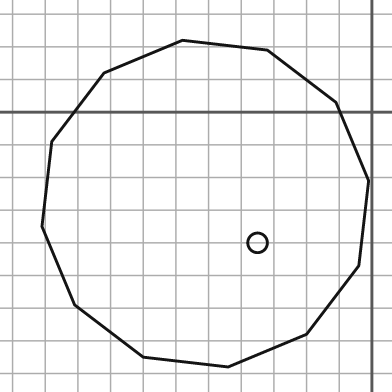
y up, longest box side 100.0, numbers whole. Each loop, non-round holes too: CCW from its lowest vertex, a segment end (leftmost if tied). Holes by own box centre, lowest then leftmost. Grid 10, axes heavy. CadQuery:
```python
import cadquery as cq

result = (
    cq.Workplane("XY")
    .moveTo(-44.0, -78.0)
    .lineTo(-20.0, -68.0)
    .lineTo(-4.0, -47.0)
    .lineTo(-1.0, -21.0)
    .lineTo(-11.0, 3.0)
    .lineTo(-32.0, 19.0)
    .lineTo(-58.0, 22.0)
    .lineTo(-82.0, 12.0)
    .lineTo(-98.0, -9.0)
    .lineTo(-101.0, -35.0)
    .lineTo(-91.0, -59.0)
    .lineTo(-70.0, -75.0)
    .close()
    .moveTo(-35.0, -40.0)
    .circle(3.0)
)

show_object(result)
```